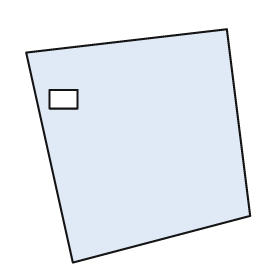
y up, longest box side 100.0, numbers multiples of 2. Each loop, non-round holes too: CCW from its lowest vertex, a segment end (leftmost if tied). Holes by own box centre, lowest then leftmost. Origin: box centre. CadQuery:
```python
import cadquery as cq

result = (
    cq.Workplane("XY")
    .moveTo(-28.0, -50.0)
    .lineTo(48.0, -30.0)
    .lineTo(38.0, 50.0)
    .lineTo(-48.0, 40.0)
    .close()
    .moveTo(-38.0, 16.0)
    .lineTo(-26.0, 16.0)
    .lineTo(-26.0, 24.0)
    .lineTo(-38.0, 24.0)
    .close()
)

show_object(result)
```